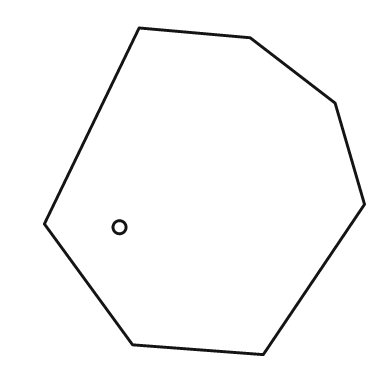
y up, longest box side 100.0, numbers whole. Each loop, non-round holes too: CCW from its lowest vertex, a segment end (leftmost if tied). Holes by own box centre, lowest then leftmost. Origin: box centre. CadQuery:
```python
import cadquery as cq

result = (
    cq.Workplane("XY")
    .moveTo(18.0, -50.0)
    .lineTo(49.0, -4.0)
    .lineTo(40.0, 27.0)
    .lineTo(14.0, 47.0)
    .lineTo(-20.0, 50.0)
    .lineTo(-49.0, -10.0)
    .lineTo(-22.0, -47.0)
    .close()
    .moveTo(-26.0, -11.0)
    .circle(2.0)
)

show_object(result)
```